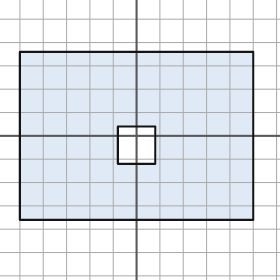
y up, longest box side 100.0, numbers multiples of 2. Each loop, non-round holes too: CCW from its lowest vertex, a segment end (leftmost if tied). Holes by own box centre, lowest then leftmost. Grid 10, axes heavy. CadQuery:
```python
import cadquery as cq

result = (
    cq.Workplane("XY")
    .moveTo(-50.0, -36.0)
    .lineTo(50.0, -36.0)
    .lineTo(50.0, 36.0)
    .lineTo(-50.0, 36.0)
    .close()
    .moveTo(-8.0, -12.0)
    .lineTo(8.0, -12.0)
    .lineTo(8.0, 4.0)
    .lineTo(-8.0, 4.0)
    .close()
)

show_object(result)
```